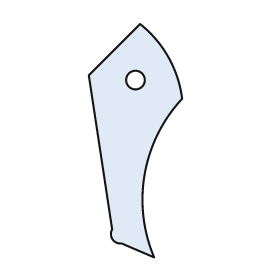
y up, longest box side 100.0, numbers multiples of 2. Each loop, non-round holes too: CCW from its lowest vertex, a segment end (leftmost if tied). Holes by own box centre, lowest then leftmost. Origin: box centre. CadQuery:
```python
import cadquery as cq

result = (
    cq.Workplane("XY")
    .moveTo(8.0, -50.0)
    .threePointArc((4.0, -14.0), (20.0, 18.0))
    .threePointArc((14.0, 36.0), (2.0, 50.0))
    .lineTo(-20.0, 28.0)
    .lineTo(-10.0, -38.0)
    .threePointArc((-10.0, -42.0), (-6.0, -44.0))
    .close()
    .moveTo(0.0, 26.0)
    .circle(4.0)
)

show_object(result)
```